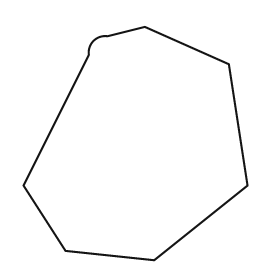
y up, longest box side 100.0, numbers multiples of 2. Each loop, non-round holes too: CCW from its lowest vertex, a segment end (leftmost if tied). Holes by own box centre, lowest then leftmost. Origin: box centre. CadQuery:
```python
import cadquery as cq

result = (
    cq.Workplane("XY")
    .moveTo(8.0, -50.0)
    .lineTo(48.0, -18.0)
    .lineTo(40.0, 34.0)
    .lineTo(4.0, 50.0)
    .lineTo(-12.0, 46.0)
    .threePointArc((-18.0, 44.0), (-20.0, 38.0))
    .lineTo(-48.0, -18.0)
    .lineTo(-30.0, -46.0)
    .close()
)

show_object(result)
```